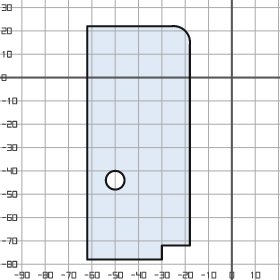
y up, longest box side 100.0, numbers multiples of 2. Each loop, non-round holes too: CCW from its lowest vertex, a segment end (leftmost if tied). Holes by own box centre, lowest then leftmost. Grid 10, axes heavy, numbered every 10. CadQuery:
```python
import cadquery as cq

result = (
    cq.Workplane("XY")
    .moveTo(-62.0, -78.0)
    .lineTo(-30.0, -78.0)
    .lineTo(-30.0, -72.0)
    .lineTo(-18.0, -72.0)
    .lineTo(-18.0, 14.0)
    .threePointArc((-20.0, 20.0), (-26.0, 22.0))
    .lineTo(-62.0, 22.0)
    .close()
    .moveTo(-50.0, -44.0)
    .circle(4.0)
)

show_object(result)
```